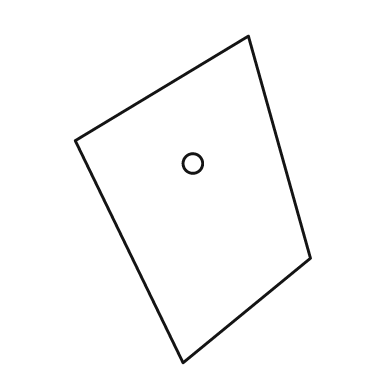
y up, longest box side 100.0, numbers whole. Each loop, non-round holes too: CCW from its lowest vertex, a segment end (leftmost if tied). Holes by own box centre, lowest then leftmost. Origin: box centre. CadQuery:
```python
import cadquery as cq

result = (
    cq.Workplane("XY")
    .moveTo(-3.0, -50.0)
    .lineTo(36.0, -18.0)
    .lineTo(17.0, 50.0)
    .lineTo(-36.0, 18.0)
    .close()
    .moveTo(0.0, 11.0)
    .circle(3.0)
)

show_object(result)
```